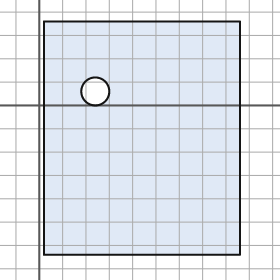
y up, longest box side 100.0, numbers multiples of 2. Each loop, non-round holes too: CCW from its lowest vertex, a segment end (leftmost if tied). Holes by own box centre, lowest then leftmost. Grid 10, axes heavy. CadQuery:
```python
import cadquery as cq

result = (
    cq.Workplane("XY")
    .moveTo(2.0, -64.0)
    .lineTo(86.0, -64.0)
    .lineTo(86.0, 36.0)
    .lineTo(2.0, 36.0)
    .close()
    .moveTo(24.0, 6.0)
    .circle(6.0)
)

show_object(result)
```